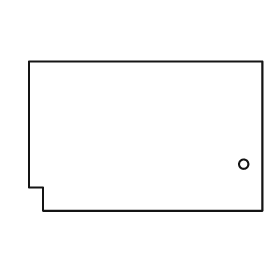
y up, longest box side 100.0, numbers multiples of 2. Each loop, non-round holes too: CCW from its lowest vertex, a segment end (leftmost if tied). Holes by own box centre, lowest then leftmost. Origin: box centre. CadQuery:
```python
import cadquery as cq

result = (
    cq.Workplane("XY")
    .moveTo(-44.0, -32.0)
    .lineTo(50.0, -32.0)
    .lineTo(50.0, 32.0)
    .lineTo(-50.0, 32.0)
    .lineTo(-50.0, -22.0)
    .lineTo(-44.0, -22.0)
    .close()
    .moveTo(42.0, -12.0)
    .circle(2.0)
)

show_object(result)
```